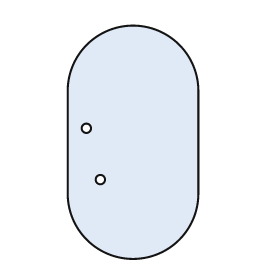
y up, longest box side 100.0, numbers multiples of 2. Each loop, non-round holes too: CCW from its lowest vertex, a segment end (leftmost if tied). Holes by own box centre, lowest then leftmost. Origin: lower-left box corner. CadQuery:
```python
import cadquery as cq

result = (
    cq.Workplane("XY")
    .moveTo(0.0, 28.0)
    .threePointArc((28.0, 0.0), (56.0, 28.0))
    .lineTo(56.0, 72.0)
    .threePointArc((28.0, 100.0), (0.0, 72.0))
    .close()
    .moveTo(14.0, 34.0)
    .circle(2.0)
    .moveTo(8.0, 56.0)
    .circle(2.0)
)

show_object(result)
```